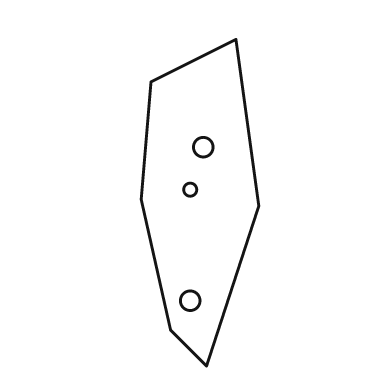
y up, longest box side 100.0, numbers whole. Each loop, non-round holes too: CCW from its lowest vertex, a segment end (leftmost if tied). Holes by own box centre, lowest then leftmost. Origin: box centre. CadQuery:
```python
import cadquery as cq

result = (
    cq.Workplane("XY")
    .moveTo(2.0, -50.0)
    .lineTo(18.0, -1.0)
    .lineTo(11.0, 50.0)
    .lineTo(-15.0, 37.0)
    .lineTo(-18.0, 1.0)
    .lineTo(-9.0, -39.0)
    .close()
    .moveTo(-3.0, -30.0)
    .circle(3.0)
    .moveTo(-3.0, 4.0)
    .circle(2.0)
    .moveTo(1.0, 17.0)
    .circle(3.0)
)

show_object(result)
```